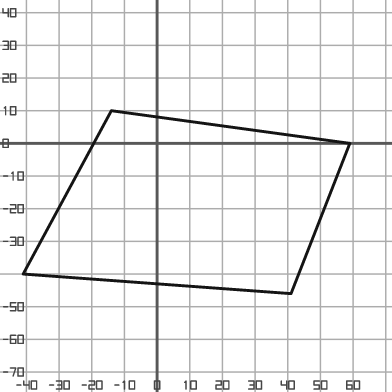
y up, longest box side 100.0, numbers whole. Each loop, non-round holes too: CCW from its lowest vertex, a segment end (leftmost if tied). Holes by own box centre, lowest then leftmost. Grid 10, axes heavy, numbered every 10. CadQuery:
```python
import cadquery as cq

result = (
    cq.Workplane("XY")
    .moveTo(41.0, -46.0)
    .lineTo(59.0, 0.0)
    .lineTo(-14.0, 10.0)
    .lineTo(-41.0, -40.0)
    .close()
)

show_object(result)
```